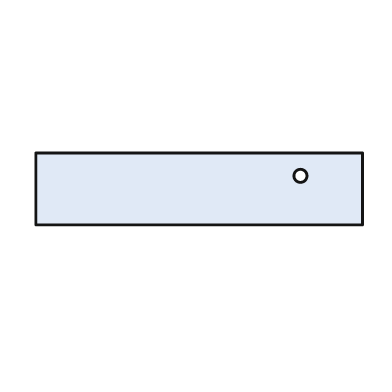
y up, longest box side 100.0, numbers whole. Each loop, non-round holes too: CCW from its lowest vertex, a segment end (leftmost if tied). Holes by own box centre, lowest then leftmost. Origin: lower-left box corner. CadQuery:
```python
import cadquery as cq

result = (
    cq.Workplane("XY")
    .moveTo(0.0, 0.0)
    .lineTo(100.0, 0.0)
    .lineTo(100.0, 22.0)
    .lineTo(0.0, 22.0)
    .close()
    .moveTo(81.0, 15.0)
    .circle(2.0)
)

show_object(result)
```